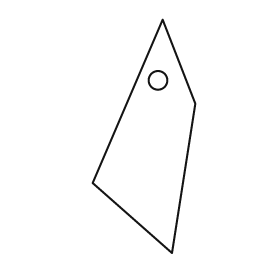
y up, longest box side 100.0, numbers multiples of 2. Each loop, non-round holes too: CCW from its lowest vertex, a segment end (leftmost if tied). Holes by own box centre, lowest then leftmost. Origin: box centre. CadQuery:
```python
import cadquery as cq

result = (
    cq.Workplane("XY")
    .moveTo(12.0, -50.0)
    .lineTo(22.0, 14.0)
    .lineTo(8.0, 50.0)
    .lineTo(-22.0, -20.0)
    .close()
    .moveTo(6.0, 24.0)
    .circle(4.0)
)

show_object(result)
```